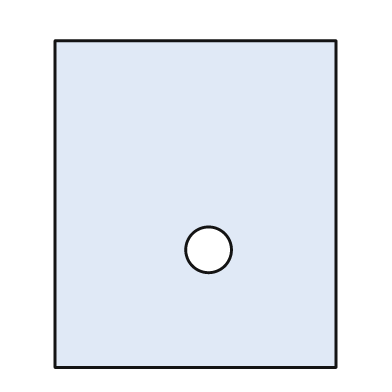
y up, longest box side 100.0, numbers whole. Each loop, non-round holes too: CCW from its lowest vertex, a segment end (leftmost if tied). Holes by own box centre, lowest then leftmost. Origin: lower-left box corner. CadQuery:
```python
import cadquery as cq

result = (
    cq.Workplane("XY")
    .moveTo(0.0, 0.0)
    .lineTo(86.0, 0.0)
    .lineTo(86.0, 100.0)
    .lineTo(0.0, 100.0)
    .close()
    .moveTo(47.0, 36.0)
    .circle(7.0)
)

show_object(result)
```